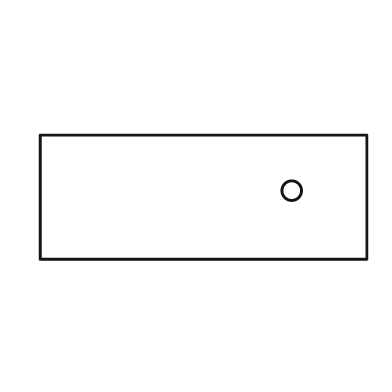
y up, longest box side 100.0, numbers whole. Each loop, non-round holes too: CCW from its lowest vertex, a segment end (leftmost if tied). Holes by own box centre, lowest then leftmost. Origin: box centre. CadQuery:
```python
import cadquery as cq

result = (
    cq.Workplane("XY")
    .moveTo(-50.0, -19.0)
    .lineTo(50.0, -19.0)
    .lineTo(50.0, 19.0)
    .lineTo(-50.0, 19.0)
    .close()
    .moveTo(27.0, 2.0)
    .circle(3.0)
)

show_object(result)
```